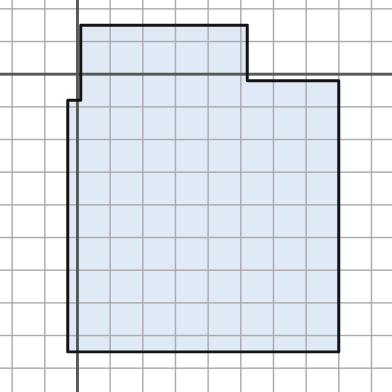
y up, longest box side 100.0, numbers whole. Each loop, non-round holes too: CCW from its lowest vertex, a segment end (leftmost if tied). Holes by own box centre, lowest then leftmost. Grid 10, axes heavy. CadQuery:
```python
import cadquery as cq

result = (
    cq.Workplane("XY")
    .moveTo(-3.0, -85.0)
    .lineTo(80.0, -85.0)
    .lineTo(80.0, -2.0)
    .lineTo(52.0, -2.0)
    .lineTo(52.0, 15.0)
    .lineTo(1.0, 15.0)
    .lineTo(1.0, -8.0)
    .lineTo(-3.0, -8.0)
    .close()
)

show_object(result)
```